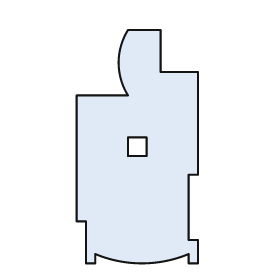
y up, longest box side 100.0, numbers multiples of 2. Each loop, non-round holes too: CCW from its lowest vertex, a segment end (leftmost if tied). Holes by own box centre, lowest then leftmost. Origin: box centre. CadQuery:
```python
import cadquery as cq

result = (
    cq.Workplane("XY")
    .moveTo(-22.0, -50.0)
    .lineTo(-18.0, -50.0)
    .lineTo(-18.0, -46.0)
    .threePointArc((2.0, -50.0), (22.0, -46.0))
    .lineTo(22.0, -50.0)
    .lineTo(26.0, -50.0)
    .lineTo(26.0, -40.0)
    .lineTo(22.0, -40.0)
    .lineTo(22.0, -12.0)
    .lineTo(26.0, -12.0)
    .lineTo(26.0, 32.0)
    .lineTo(10.0, 32.0)
    .lineTo(10.0, 50.0)
    .lineTo(-4.0, 50.0)
    .threePointArc((-8.0, 36.0), (-4.0, 22.0))
    .lineTo(-26.0, 22.0)
    .lineTo(-26.0, -32.0)
    .lineTo(-22.0, -32.0)
    .close()
    .moveTo(-4.0, -4.0)
    .lineTo(4.0, -4.0)
    .lineTo(4.0, 4.0)
    .lineTo(-4.0, 4.0)
    .close()
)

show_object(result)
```